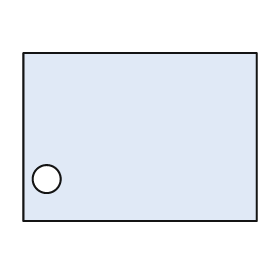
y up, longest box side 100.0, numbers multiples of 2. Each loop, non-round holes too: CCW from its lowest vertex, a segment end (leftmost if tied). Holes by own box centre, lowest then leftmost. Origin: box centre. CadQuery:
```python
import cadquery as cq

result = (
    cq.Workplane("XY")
    .moveTo(-50.0, -36.0)
    .lineTo(50.0, -36.0)
    .lineTo(50.0, 36.0)
    .lineTo(-50.0, 36.0)
    .close()
    .moveTo(-40.0, -18.0)
    .circle(6.0)
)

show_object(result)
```